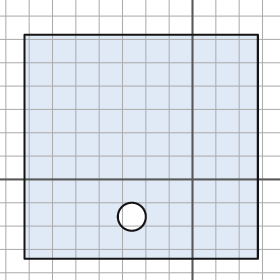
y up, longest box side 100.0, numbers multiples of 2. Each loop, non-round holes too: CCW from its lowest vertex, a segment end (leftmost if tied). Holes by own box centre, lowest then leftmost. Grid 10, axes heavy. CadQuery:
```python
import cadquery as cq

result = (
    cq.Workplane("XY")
    .moveTo(-72.0, -34.0)
    .lineTo(28.0, -34.0)
    .lineTo(28.0, 62.0)
    .lineTo(-72.0, 62.0)
    .close()
    .moveTo(-26.0, -16.0)
    .circle(6.0)
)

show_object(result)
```